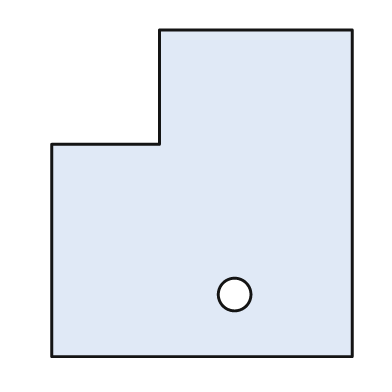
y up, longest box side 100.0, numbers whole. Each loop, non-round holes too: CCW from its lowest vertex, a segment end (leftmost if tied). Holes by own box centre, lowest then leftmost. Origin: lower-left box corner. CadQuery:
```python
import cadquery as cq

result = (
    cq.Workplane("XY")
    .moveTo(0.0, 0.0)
    .lineTo(92.0, 0.0)
    .lineTo(92.0, 100.0)
    .lineTo(33.0, 100.0)
    .lineTo(33.0, 65.0)
    .lineTo(0.0, 65.0)
    .close()
    .moveTo(56.0, 19.0)
    .circle(5.0)
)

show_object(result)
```